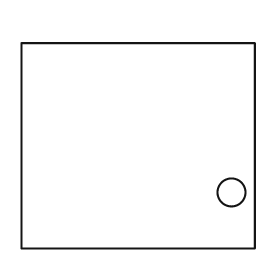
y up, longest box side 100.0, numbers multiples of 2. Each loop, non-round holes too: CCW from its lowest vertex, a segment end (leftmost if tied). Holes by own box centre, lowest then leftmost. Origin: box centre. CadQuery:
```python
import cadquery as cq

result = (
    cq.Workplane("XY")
    .moveTo(-50.0, -44.0)
    .lineTo(50.0, -44.0)
    .lineTo(50.0, 44.0)
    .lineTo(-50.0, 44.0)
    .close()
    .moveTo(40.0, -20.0)
    .circle(6.0)
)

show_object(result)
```